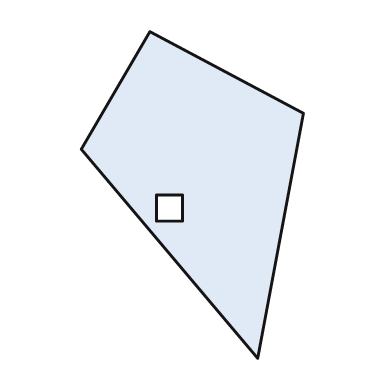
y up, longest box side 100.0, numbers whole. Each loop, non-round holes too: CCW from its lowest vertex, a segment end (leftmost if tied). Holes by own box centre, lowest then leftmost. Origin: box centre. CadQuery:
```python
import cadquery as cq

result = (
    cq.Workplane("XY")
    .moveTo(20.0, -50.0)
    .lineTo(34.0, 25.0)
    .lineTo(-13.0, 50.0)
    .lineTo(-34.0, 14.0)
    .close()
    .moveTo(-11.0, -8.0)
    .lineTo(-3.0, -8.0)
    .lineTo(-3.0, 0.0)
    .lineTo(-11.0, 0.0)
    .close()
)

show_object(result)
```